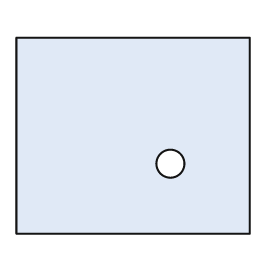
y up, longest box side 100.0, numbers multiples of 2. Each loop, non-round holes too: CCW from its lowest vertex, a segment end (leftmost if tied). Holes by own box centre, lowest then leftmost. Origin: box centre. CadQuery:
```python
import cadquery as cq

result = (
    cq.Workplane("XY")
    .moveTo(-50.0, -42.0)
    .lineTo(50.0, -42.0)
    .lineTo(50.0, 42.0)
    .lineTo(-50.0, 42.0)
    .close()
    .moveTo(16.0, -12.0)
    .circle(6.0)
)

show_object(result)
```